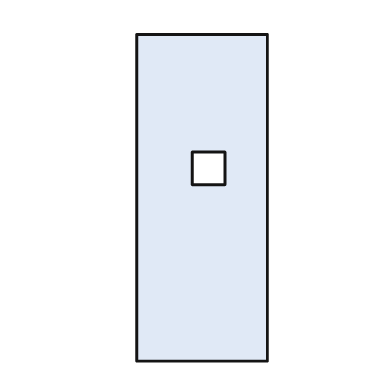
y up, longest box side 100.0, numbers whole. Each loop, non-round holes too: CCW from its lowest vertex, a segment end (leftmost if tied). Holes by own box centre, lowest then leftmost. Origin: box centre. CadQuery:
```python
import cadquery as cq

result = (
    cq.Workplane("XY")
    .moveTo(-20.0, -50.0)
    .lineTo(20.0, -50.0)
    .lineTo(20.0, 50.0)
    .lineTo(-20.0, 50.0)
    .close()
    .moveTo(-3.0, 4.0)
    .lineTo(7.0, 4.0)
    .lineTo(7.0, 14.0)
    .lineTo(-3.0, 14.0)
    .close()
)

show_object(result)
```